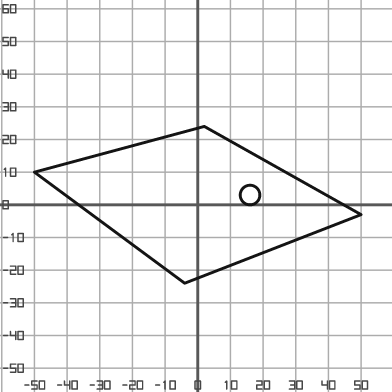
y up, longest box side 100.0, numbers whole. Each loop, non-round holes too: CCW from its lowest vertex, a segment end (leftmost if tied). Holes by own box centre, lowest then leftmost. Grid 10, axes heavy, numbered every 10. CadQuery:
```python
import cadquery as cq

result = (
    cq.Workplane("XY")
    .moveTo(-4.0, -24.0)
    .lineTo(50.0, -3.0)
    .lineTo(2.0, 24.0)
    .lineTo(-50.0, 10.0)
    .close()
    .moveTo(16.0, 3.0)
    .circle(3.0)
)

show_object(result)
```